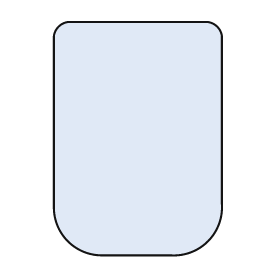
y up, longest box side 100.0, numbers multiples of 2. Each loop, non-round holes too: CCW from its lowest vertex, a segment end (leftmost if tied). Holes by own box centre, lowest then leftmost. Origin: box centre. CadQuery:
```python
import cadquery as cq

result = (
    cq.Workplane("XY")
    .moveTo(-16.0, -50.0)
    .lineTo(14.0, -50.0)
    .threePointArc((30.0, -44.0), (36.0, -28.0))
    .lineTo(36.0, 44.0)
    .threePointArc((34.0, 48.0), (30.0, 50.0))
    .lineTo(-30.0, 50.0)
    .threePointArc((-34.0, 48.0), (-36.0, 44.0))
    .lineTo(-36.0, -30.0)
    .threePointArc((-30.0, -44.0), (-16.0, -50.0))
    .close()
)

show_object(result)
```